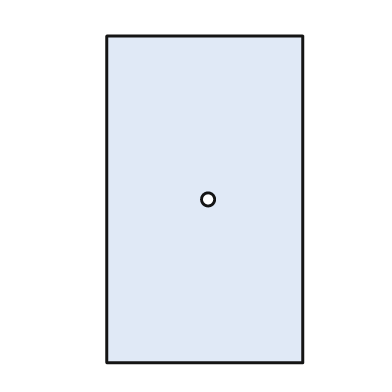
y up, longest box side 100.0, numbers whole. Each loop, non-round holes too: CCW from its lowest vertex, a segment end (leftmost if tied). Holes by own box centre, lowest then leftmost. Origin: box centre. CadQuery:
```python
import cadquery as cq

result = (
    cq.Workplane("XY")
    .moveTo(-30.0, -50.0)
    .lineTo(30.0, -50.0)
    .lineTo(30.0, 50.0)
    .lineTo(-30.0, 50.0)
    .close()
    .moveTo(1.0, 0.0)
    .circle(2.0)
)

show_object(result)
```